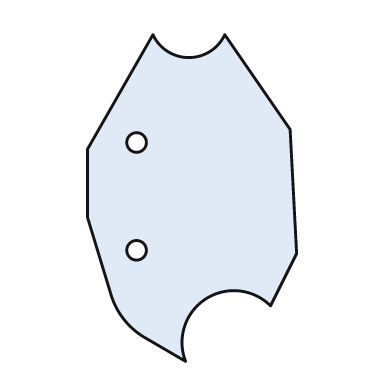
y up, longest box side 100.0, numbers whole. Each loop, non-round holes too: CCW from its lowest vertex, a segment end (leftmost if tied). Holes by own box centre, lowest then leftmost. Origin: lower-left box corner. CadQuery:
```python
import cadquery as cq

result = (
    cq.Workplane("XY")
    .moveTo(30.0, 0.0)
    .threePointArc((36.0, 19.0), (56.0, 17.0))
    .lineTo(64.0, 33.0)
    .lineTo(62.0, 71.0)
    .lineTo(42.0, 100.0)
    .threePointArc((31.0, 93.0), (20.0, 100.0))
    .lineTo(0.0, 65.0)
    .lineTo(0.0, 44.0)
    .lineTo(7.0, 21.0)
    .threePointArc((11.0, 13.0), (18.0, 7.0))
    .close()
    .moveTo(15.0, 34.0)
    .circle(3.0)
    .moveTo(15.0, 67.0)
    .circle(3.0)
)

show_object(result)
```